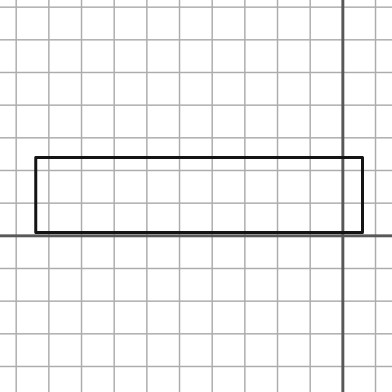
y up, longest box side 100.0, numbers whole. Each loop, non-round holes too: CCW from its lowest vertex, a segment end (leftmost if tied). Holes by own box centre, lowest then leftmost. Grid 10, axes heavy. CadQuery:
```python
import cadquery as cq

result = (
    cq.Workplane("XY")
    .moveTo(-94.0, 1.0)
    .lineTo(6.0, 1.0)
    .lineTo(6.0, 24.0)
    .lineTo(-94.0, 24.0)
    .close()
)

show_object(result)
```